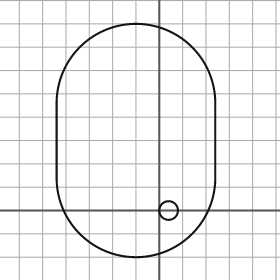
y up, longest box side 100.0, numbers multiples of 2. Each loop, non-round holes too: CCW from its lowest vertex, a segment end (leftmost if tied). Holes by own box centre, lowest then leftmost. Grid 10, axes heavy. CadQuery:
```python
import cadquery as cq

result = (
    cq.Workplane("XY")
    .moveTo(-44.0, 14.0)
    .threePointArc((-10.0, -20.0), (24.0, 14.0))
    .lineTo(24.0, 46.0)
    .threePointArc((-10.0, 80.0), (-44.0, 46.0))
    .close()
    .moveTo(4.0, 0.0)
    .circle(4.0)
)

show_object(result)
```